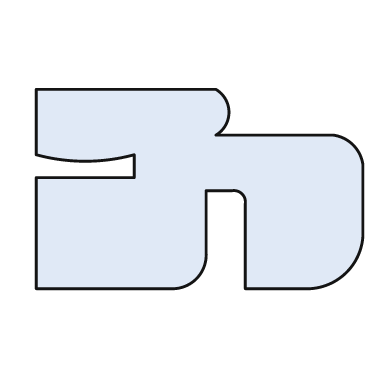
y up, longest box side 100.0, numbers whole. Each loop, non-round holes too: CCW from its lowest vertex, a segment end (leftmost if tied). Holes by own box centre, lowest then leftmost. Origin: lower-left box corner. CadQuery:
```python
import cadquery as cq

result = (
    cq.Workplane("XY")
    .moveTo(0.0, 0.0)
    .lineTo(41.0, 0.0)
    .threePointArc((49.0, 3.0), (52.0, 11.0))
    .lineTo(52.0, 30.0)
    .lineTo(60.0, 30.0)
    .threePointArc((63.0, 29.0), (64.0, 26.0))
    .lineTo(64.0, 0.0)
    .lineTo(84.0, 0.0)
    .threePointArc((95.0, 5.0), (100.0, 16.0))
    .lineTo(100.0, 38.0)
    .threePointArc((97.0, 44.0), (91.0, 47.0))
    .lineTo(55.0, 47.0)
    .threePointArc((59.0, 54.0), (55.0, 61.0))
    .lineTo(0.0, 61.0)
    .lineTo(0.0, 41.0)
    .threePointArc((15.0, 39.0), (30.0, 41.0))
    .lineTo(30.0, 34.0)
    .lineTo(0.0, 34.0)
    .close()
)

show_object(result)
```